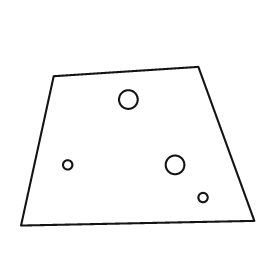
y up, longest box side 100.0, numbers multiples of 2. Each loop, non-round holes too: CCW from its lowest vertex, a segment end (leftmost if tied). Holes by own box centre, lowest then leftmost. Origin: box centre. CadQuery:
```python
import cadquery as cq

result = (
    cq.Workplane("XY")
    .moveTo(-50.0, -34.0)
    .lineTo(50.0, -32.0)
    .lineTo(26.0, 34.0)
    .lineTo(-36.0, 30.0)
    .close()
    .moveTo(28.0, -22.0)
    .circle(2.0)
    .moveTo(-30.0, -8.0)
    .circle(2.0)
    .moveTo(16.0, -8.0)
    .circle(4.0)
    .moveTo(-4.0, 20.0)
    .circle(4.0)
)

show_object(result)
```